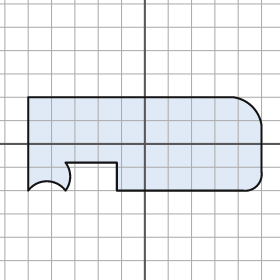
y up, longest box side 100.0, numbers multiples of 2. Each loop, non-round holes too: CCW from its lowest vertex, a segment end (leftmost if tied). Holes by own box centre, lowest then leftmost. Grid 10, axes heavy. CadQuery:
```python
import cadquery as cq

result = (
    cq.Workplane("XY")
    .moveTo(-50.0, -20.0)
    .threePointArc((-42.0, -16.0), (-34.0, -20.0))
    .threePointArc((-32.0, -14.0), (-34.0, -8.0))
    .lineTo(-12.0, -8.0)
    .lineTo(-12.0, -20.0)
    .lineTo(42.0, -20.0)
    .threePointArc((48.0, -18.0), (50.0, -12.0))
    .lineTo(50.0, 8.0)
    .threePointArc((46.0, 16.0), (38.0, 20.0))
    .lineTo(-50.0, 20.0)
    .close()
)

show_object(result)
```